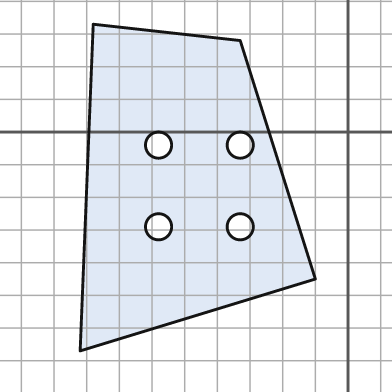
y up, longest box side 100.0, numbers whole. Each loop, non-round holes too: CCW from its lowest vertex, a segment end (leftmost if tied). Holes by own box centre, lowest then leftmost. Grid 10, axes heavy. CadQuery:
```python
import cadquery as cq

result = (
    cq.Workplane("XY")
    .moveTo(-82.0, -67.0)
    .lineTo(-10.0, -45.0)
    .lineTo(-33.0, 28.0)
    .lineTo(-78.0, 33.0)
    .close()
    .moveTo(-58.0, -29.0)
    .circle(4.0)
    .moveTo(-33.0, -29.0)
    .circle(4.0)
    .moveTo(-58.0, -4.0)
    .circle(4.0)
    .moveTo(-33.0, -4.0)
    .circle(4.0)
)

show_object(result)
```